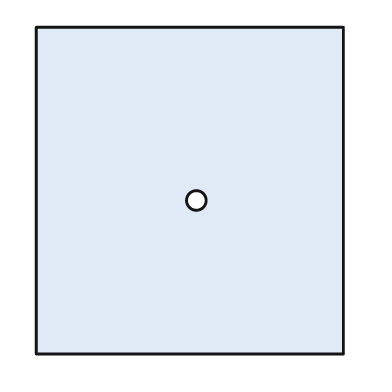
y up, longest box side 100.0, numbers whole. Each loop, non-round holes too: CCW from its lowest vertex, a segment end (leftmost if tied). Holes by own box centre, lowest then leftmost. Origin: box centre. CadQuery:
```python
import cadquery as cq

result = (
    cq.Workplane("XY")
    .moveTo(-47.0, -50.0)
    .lineTo(47.0, -50.0)
    .lineTo(47.0, 50.0)
    .lineTo(-47.0, 50.0)
    .close()
    .moveTo(2.0, -3.0)
    .circle(3.0)
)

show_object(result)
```